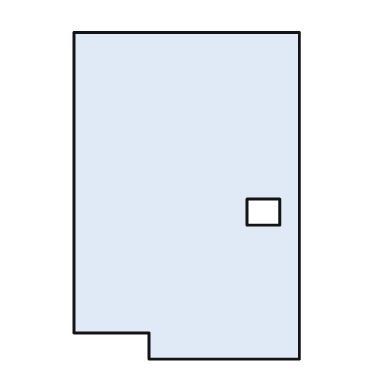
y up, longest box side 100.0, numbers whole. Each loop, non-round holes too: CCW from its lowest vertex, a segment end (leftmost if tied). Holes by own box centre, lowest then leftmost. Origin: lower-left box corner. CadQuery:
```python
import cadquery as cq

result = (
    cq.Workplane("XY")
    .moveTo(23.0, 0.0)
    .lineTo(69.0, 0.0)
    .lineTo(69.0, 100.0)
    .lineTo(0.0, 100.0)
    .lineTo(0.0, 8.0)
    .lineTo(23.0, 8.0)
    .close()
    .moveTo(53.0, 41.0)
    .lineTo(63.0, 41.0)
    .lineTo(63.0, 49.0)
    .lineTo(53.0, 49.0)
    .close()
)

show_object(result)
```